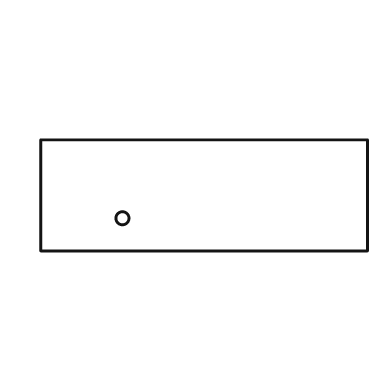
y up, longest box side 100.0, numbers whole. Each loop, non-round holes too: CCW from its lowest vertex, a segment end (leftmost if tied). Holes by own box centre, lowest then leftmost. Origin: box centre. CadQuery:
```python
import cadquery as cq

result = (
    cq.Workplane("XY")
    .moveTo(-50.0, -17.0)
    .lineTo(50.0, -17.0)
    .lineTo(50.0, 17.0)
    .lineTo(-50.0, 17.0)
    .close()
    .moveTo(-25.0, -7.0)
    .circle(2.0)
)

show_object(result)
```